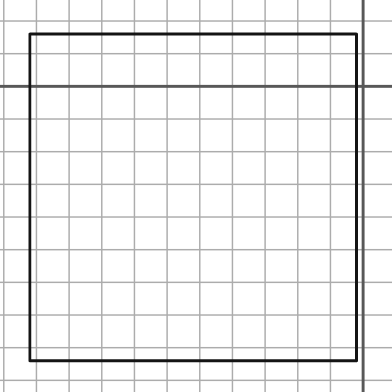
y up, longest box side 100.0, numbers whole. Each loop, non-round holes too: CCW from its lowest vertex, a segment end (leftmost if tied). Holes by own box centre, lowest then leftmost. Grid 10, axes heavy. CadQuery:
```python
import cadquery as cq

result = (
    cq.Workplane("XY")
    .moveTo(-102.0, -84.0)
    .lineTo(-2.0, -84.0)
    .lineTo(-2.0, 16.0)
    .lineTo(-102.0, 16.0)
    .close()
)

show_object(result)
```